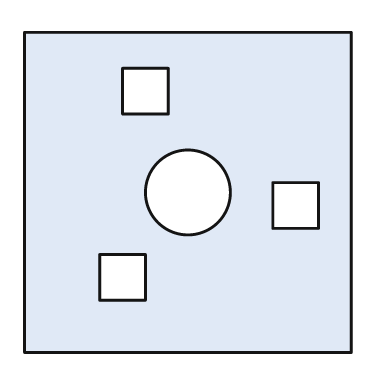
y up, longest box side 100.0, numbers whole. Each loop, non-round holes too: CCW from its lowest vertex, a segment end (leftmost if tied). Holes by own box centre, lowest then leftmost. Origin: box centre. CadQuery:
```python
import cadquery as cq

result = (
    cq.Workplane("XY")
    .moveTo(-50.0, -49.0)
    .lineTo(50.0, -49.0)
    .lineTo(50.0, 49.0)
    .lineTo(-50.0, 49.0)
    .close()
    .moveTo(-27.0, -33.0)
    .lineTo(-13.0, -33.0)
    .lineTo(-13.0, -19.0)
    .lineTo(-27.0, -19.0)
    .close()
    .moveTo(26.0, -11.0)
    .lineTo(40.0, -11.0)
    .lineTo(40.0, 3.0)
    .lineTo(26.0, 3.0)
    .close()
    .moveTo(0.0, 0.0)
    .circle(13.0)
    .moveTo(-20.0, 24.0)
    .lineTo(-6.0, 24.0)
    .lineTo(-6.0, 38.0)
    .lineTo(-20.0, 38.0)
    .close()
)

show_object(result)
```